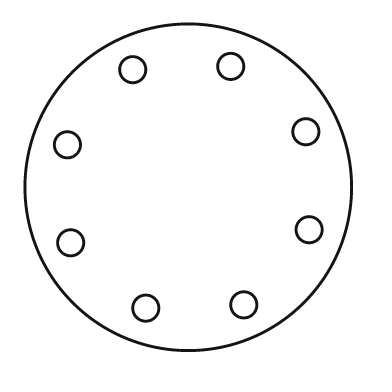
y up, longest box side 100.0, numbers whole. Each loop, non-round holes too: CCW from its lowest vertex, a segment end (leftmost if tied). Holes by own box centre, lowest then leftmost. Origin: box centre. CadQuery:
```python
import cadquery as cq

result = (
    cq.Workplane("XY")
    .moveTo(0.0, 0.0)
    .circle(50.0)
    .moveTo(-13.0, -37.0)
    .circle(4.0)
    .moveTo(17.0, -36.0)
    .circle(4.0)
    .moveTo(-36.0, -17.0)
    .circle(4.0)
    .moveTo(37.0, -13.0)
    .circle(4.0)
    .moveTo(-37.0, 13.0)
    .circle(4.0)
    .moveTo(36.0, 17.0)
    .circle(4.0)
    .moveTo(-17.0, 36.0)
    .circle(4.0)
    .moveTo(13.0, 37.0)
    .circle(4.0)
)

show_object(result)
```